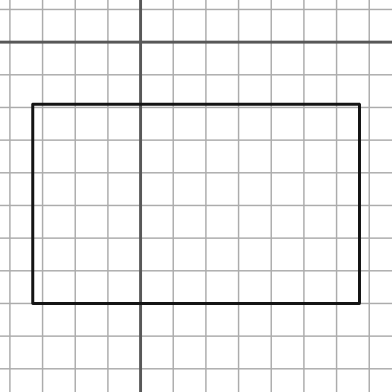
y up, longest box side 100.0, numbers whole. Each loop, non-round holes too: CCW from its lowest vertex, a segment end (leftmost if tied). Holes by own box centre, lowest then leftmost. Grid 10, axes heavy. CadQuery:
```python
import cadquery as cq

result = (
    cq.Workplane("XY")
    .moveTo(-33.0, -80.0)
    .lineTo(67.0, -80.0)
    .lineTo(67.0, -19.0)
    .lineTo(-33.0, -19.0)
    .close()
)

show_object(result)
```